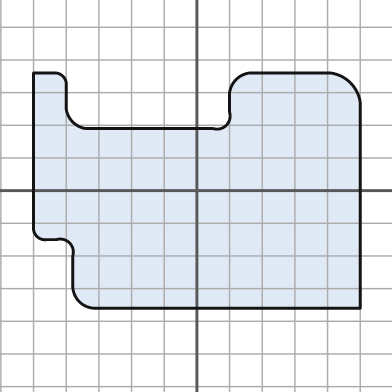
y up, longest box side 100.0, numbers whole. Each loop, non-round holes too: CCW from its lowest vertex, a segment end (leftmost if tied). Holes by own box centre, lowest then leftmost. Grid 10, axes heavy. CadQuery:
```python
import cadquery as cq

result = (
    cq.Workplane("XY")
    .moveTo(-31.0, -36.0)
    .lineTo(50.0, -36.0)
    .lineTo(50.0, 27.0)
    .threePointArc((47.0, 33.0), (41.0, 36.0))
    .lineTo(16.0, 36.0)
    .threePointArc((12.0, 34.0), (10.0, 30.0))
    .lineTo(10.0, 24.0)
    .threePointArc((9.0, 20.0), (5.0, 19.0))
    .lineTo(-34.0, 19.0)
    .threePointArc((-38.0, 21.0), (-40.0, 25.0))
    .lineTo(-40.0, 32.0)
    .threePointArc((-41.0, 35.0), (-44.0, 36.0))
    .lineTo(-50.0, 36.0)
    .lineTo(-50.0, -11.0)
    .threePointArc((-49.0, -14.0), (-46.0, -15.0))
    .lineTo(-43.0, -15.0)
    .threePointArc((-39.0, -16.0), (-38.0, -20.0))
    .lineTo(-38.0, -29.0)
    .threePointArc((-36.0, -34.0), (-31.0, -36.0))
    .close()
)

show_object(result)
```